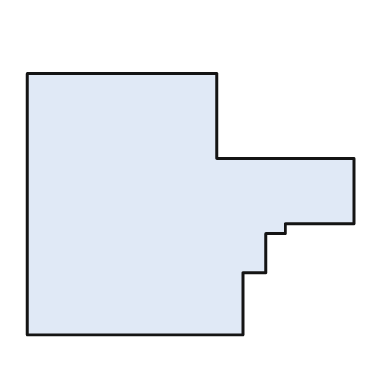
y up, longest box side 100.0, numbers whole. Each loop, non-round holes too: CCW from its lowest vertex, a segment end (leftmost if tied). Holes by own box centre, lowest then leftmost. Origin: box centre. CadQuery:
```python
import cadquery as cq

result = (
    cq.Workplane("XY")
    .moveTo(-50.0, -40.0)
    .lineTo(16.0, -40.0)
    .lineTo(16.0, -21.0)
    .lineTo(23.0, -21.0)
    .lineTo(23.0, -9.0)
    .lineTo(29.0, -9.0)
    .lineTo(29.0, -6.0)
    .lineTo(50.0, -6.0)
    .lineTo(50.0, 14.0)
    .lineTo(8.0, 14.0)
    .lineTo(8.0, 40.0)
    .lineTo(-50.0, 40.0)
    .close()
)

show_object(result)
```